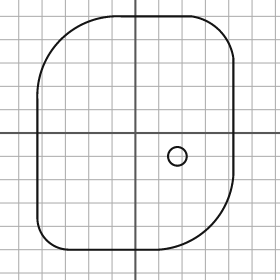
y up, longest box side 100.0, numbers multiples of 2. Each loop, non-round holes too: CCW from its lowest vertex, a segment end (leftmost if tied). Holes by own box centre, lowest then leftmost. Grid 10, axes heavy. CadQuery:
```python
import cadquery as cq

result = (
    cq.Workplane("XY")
    .moveTo(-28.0, -50.0)
    .lineTo(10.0, -50.0)
    .threePointArc((32.0, -40.0), (42.0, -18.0))
    .lineTo(42.0, 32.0)
    .threePointArc((36.0, 44.0), (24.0, 50.0))
    .lineTo(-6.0, 50.0)
    .threePointArc((-32.0, 40.0), (-42.0, 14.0))
    .lineTo(-42.0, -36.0)
    .threePointArc((-38.0, -46.0), (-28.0, -50.0))
    .close()
    .moveTo(18.0, -10.0)
    .circle(4.0)
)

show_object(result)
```